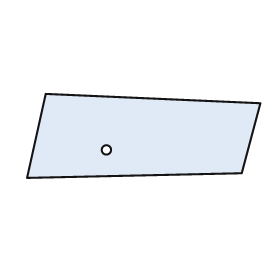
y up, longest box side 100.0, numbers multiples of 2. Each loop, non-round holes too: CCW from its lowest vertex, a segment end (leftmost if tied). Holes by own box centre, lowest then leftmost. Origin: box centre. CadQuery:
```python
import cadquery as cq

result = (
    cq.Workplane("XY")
    .moveTo(-50.0, -18.0)
    .lineTo(42.0, -16.0)
    .lineTo(50.0, 14.0)
    .lineTo(-42.0, 18.0)
    .close()
    .moveTo(-16.0, -6.0)
    .circle(2.0)
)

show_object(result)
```